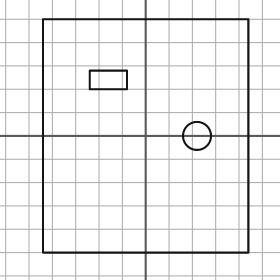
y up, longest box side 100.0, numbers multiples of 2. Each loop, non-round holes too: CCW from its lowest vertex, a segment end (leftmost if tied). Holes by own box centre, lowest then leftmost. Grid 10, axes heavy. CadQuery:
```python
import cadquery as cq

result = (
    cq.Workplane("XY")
    .moveTo(-44.0, -50.0)
    .lineTo(44.0, -50.0)
    .lineTo(44.0, 50.0)
    .lineTo(-44.0, 50.0)
    .close()
    .moveTo(22.0, 0.0)
    .circle(6.0)
    .moveTo(-24.0, 20.0)
    .lineTo(-8.0, 20.0)
    .lineTo(-8.0, 28.0)
    .lineTo(-24.0, 28.0)
    .close()
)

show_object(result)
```